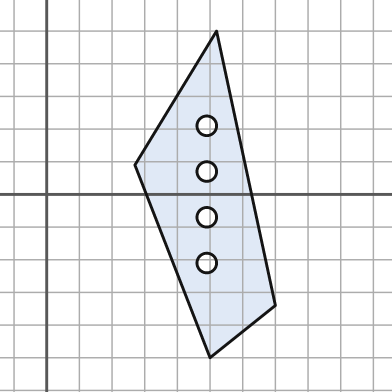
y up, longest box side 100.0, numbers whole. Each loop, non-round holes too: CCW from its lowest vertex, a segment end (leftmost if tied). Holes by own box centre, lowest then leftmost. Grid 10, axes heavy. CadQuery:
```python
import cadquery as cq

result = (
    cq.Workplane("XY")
    .moveTo(50.0, -50.0)
    .lineTo(70.0, -34.0)
    .lineTo(52.0, 50.0)
    .lineTo(27.0, 9.0)
    .close()
    .moveTo(49.0, -21.0)
    .circle(3.0)
    .moveTo(49.0, -7.0)
    .circle(3.0)
    .moveTo(49.0, 7.0)
    .circle(3.0)
    .moveTo(49.0, 21.0)
    .circle(3.0)
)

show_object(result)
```